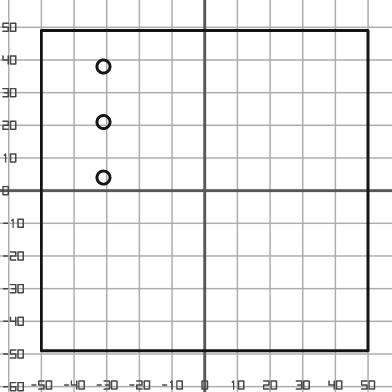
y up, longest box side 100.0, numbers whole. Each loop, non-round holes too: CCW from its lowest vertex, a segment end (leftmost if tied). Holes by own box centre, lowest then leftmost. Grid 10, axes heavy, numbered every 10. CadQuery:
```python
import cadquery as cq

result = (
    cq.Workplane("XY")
    .moveTo(-50.0, -49.0)
    .lineTo(50.0, -49.0)
    .lineTo(50.0, 49.0)
    .lineTo(-50.0, 49.0)
    .close()
    .moveTo(-31.0, 4.0)
    .circle(2.0)
    .moveTo(-31.0, 21.0)
    .circle(2.0)
    .moveTo(-31.0, 38.0)
    .circle(2.0)
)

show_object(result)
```